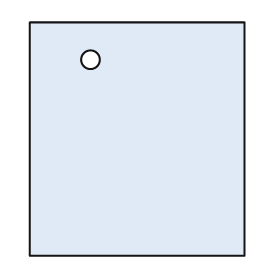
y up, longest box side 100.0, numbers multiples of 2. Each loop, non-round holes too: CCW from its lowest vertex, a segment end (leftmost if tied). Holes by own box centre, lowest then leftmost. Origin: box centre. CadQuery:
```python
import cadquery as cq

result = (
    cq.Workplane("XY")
    .moveTo(-46.0, -50.0)
    .lineTo(46.0, -50.0)
    .lineTo(46.0, 50.0)
    .lineTo(-46.0, 50.0)
    .close()
    .moveTo(-20.0, 34.0)
    .circle(4.0)
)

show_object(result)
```